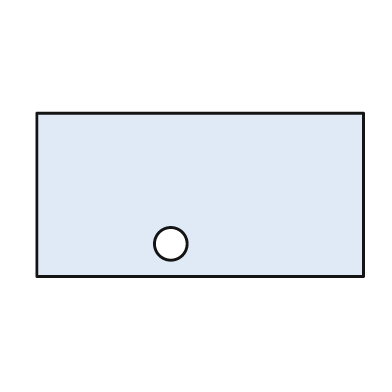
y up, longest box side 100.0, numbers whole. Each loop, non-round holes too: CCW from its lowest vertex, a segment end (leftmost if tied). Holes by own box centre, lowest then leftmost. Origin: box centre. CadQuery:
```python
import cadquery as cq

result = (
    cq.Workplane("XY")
    .moveTo(-50.0, -25.0)
    .lineTo(50.0, -25.0)
    .lineTo(50.0, 25.0)
    .lineTo(-50.0, 25.0)
    .close()
    .moveTo(-9.0, -15.0)
    .circle(5.0)
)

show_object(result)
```